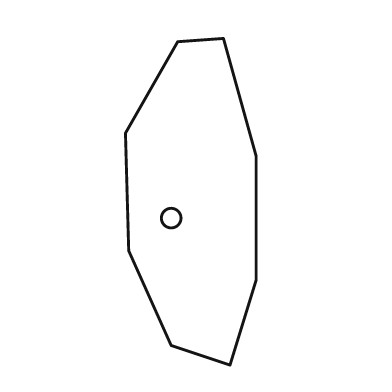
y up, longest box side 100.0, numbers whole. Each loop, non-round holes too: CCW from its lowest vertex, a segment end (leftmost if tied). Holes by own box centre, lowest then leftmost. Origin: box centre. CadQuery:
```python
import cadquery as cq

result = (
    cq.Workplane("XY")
    .moveTo(12.0, -50.0)
    .lineTo(20.0, -24.0)
    .lineTo(20.0, 14.0)
    .lineTo(10.0, 50.0)
    .lineTo(-4.0, 49.0)
    .lineTo(-20.0, 21.0)
    .lineTo(-19.0, -15.0)
    .lineTo(-6.0, -44.0)
    .close()
    .moveTo(-6.0, -5.0)
    .circle(3.0)
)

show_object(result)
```